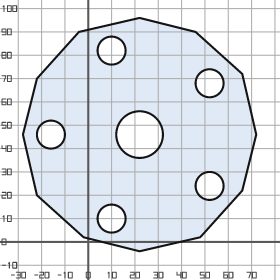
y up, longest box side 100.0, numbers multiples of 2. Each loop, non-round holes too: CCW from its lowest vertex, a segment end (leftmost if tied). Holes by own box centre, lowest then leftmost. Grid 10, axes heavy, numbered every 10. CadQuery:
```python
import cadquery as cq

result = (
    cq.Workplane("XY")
    .moveTo(22.0, -4.0)
    .lineTo(48.0, 2.0)
    .lineTo(66.0, 22.0)
    .lineTo(72.0, 46.0)
    .lineTo(66.0, 72.0)
    .lineTo(46.0, 90.0)
    .lineTo(22.0, 96.0)
    .lineTo(-4.0, 90.0)
    .lineTo(-22.0, 70.0)
    .lineTo(-28.0, 46.0)
    .lineTo(-22.0, 20.0)
    .lineTo(-2.0, 2.0)
    .close()
    .moveTo(10.0, 10.0)
    .circle(6.0)
    .moveTo(52.0, 24.0)
    .circle(6.0)
    .moveTo(-16.0, 46.0)
    .circle(6.0)
    .moveTo(22.0, 46.0)
    .circle(10.0)
    .moveTo(52.0, 68.0)
    .circle(6.0)
    .moveTo(10.0, 82.0)
    .circle(6.0)
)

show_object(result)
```